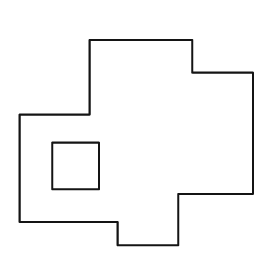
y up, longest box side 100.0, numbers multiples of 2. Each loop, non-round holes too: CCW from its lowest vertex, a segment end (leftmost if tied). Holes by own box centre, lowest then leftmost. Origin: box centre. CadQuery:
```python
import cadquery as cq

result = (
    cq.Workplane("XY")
    .moveTo(-8.0, -44.0)
    .lineTo(18.0, -44.0)
    .lineTo(18.0, -22.0)
    .lineTo(50.0, -22.0)
    .lineTo(50.0, 30.0)
    .lineTo(24.0, 30.0)
    .lineTo(24.0, 44.0)
    .lineTo(-20.0, 44.0)
    .lineTo(-20.0, 12.0)
    .lineTo(-50.0, 12.0)
    .lineTo(-50.0, -34.0)
    .lineTo(-8.0, -34.0)
    .close()
    .moveTo(-36.0, -20.0)
    .lineTo(-16.0, -20.0)
    .lineTo(-16.0, 0.0)
    .lineTo(-36.0, 0.0)
    .close()
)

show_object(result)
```